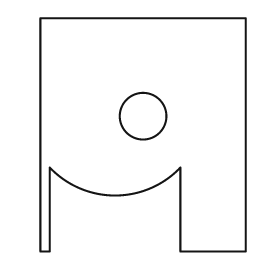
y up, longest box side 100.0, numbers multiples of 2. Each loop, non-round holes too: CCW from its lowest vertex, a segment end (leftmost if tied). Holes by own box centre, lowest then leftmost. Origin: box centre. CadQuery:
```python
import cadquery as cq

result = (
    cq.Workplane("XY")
    .moveTo(-44.0, -50.0)
    .lineTo(-40.0, -50.0)
    .lineTo(-40.0, -14.0)
    .threePointArc((-12.0, -26.0), (16.0, -14.0))
    .lineTo(16.0, -50.0)
    .lineTo(44.0, -50.0)
    .lineTo(44.0, 50.0)
    .lineTo(-44.0, 50.0)
    .close()
    .moveTo(0.0, 8.0)
    .circle(10.0)
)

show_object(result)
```